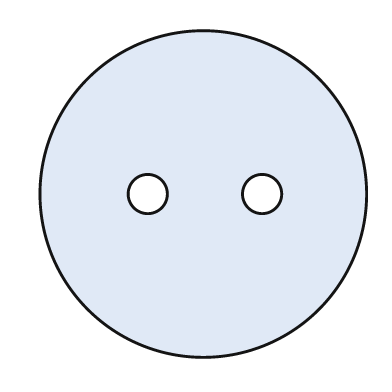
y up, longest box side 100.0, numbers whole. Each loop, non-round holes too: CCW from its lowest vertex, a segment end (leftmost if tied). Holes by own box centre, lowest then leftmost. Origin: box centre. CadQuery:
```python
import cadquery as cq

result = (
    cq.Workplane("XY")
    .moveTo(0.0, 0.0)
    .circle(50.0)
    .moveTo(-17.0, 0.0)
    .circle(6.0)
    .moveTo(18.0, 0.0)
    .circle(6.0)
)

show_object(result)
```